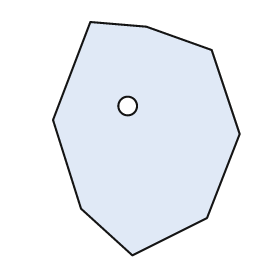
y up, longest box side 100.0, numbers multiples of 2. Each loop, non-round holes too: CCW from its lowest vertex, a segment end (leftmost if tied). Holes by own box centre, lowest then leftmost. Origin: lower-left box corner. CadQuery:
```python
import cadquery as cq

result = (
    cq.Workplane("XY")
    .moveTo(34.0, 0.0)
    .lineTo(66.0, 16.0)
    .lineTo(80.0, 52.0)
    .lineTo(68.0, 88.0)
    .lineTo(40.0, 98.0)
    .lineTo(16.0, 100.0)
    .lineTo(0.0, 58.0)
    .lineTo(12.0, 20.0)
    .close()
    .moveTo(32.0, 64.0)
    .circle(4.0)
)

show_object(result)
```